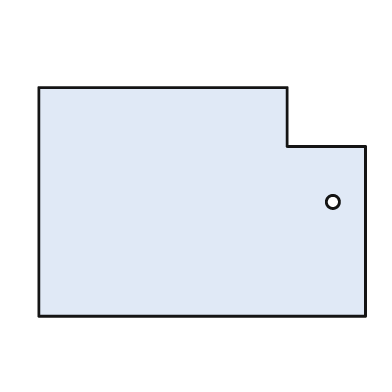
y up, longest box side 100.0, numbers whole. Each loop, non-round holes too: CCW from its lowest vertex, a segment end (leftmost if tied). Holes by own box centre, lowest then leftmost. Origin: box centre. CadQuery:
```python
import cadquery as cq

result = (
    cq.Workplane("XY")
    .moveTo(-50.0, -35.0)
    .lineTo(50.0, -35.0)
    .lineTo(50.0, 17.0)
    .lineTo(26.0, 17.0)
    .lineTo(26.0, 35.0)
    .lineTo(-50.0, 35.0)
    .close()
    .moveTo(40.0, 0.0)
    .circle(2.0)
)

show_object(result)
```